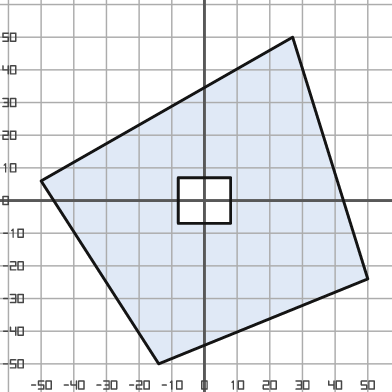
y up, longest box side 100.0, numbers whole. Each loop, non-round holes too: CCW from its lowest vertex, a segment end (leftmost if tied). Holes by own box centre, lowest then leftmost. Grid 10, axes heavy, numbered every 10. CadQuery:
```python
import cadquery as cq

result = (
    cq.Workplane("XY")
    .moveTo(-14.0, -50.0)
    .lineTo(50.0, -24.0)
    .lineTo(27.0, 50.0)
    .lineTo(-50.0, 6.0)
    .close()
    .moveTo(-8.0, -7.0)
    .lineTo(8.0, -7.0)
    .lineTo(8.0, 7.0)
    .lineTo(-8.0, 7.0)
    .close()
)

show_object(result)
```